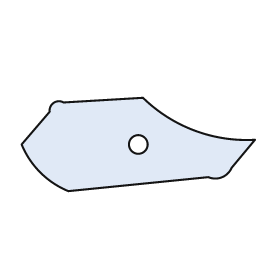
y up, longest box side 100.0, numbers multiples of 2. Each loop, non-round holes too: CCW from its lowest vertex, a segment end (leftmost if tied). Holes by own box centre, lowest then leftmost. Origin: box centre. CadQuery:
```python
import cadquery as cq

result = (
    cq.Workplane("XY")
    .moveTo(-30.0, -20.0)
    .lineTo(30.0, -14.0)
    .threePointArc((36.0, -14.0), (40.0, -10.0))
    .lineTo(50.0, 2.0)
    .threePointArc((24.0, 6.0), (2.0, 20.0))
    .lineTo(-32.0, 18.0)
    .threePointArc((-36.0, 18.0), (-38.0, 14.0))
    .lineTo(-50.0, 0.0)
    .threePointArc((-42.0, -12.0), (-30.0, -20.0))
    .close()
    .moveTo(0.0, 0.0)
    .circle(4.0)
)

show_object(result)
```